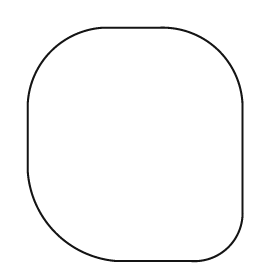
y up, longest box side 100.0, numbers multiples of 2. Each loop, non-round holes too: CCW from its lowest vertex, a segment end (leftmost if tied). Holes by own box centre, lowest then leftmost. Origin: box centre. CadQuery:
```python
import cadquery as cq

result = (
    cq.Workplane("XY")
    .moveTo(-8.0, -50.0)
    .lineTo(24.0, -50.0)
    .threePointArc((40.0, -44.0), (46.0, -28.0))
    .lineTo(46.0, 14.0)
    .threePointArc((36.0, 40.0), (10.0, 50.0))
    .lineTo(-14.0, 50.0)
    .threePointArc((-36.0, 40.0), (-46.0, 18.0))
    .lineTo(-46.0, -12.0)
    .threePointArc((-34.0, -38.0), (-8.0, -50.0))
    .close()
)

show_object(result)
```